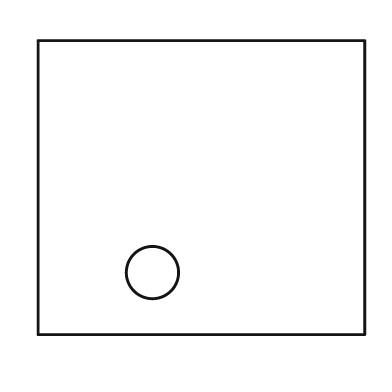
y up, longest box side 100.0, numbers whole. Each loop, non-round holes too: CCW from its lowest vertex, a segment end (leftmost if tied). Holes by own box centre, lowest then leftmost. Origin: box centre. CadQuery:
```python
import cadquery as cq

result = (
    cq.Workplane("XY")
    .moveTo(-50.0, -45.0)
    .lineTo(50.0, -45.0)
    .lineTo(50.0, 45.0)
    .lineTo(-50.0, 45.0)
    .close()
    .moveTo(-15.0, -26.0)
    .circle(8.0)
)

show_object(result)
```